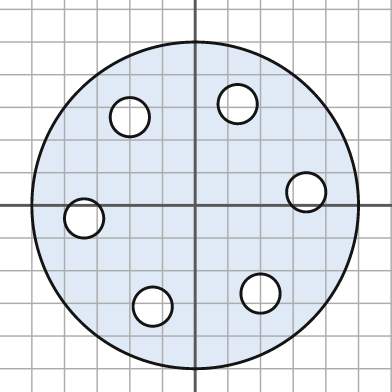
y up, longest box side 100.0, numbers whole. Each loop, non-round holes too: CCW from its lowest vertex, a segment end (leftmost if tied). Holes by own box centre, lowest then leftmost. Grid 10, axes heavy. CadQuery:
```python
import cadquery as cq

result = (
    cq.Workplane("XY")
    .moveTo(0.0, 0.0)
    .circle(50.0)
    .moveTo(-13.0, -31.0)
    .circle(6.0)
    .moveTo(20.0, -27.0)
    .circle(6.0)
    .moveTo(-34.0, -4.0)
    .circle(6.0)
    .moveTo(34.0, 4.0)
    .circle(6.0)
    .moveTo(-20.0, 27.0)
    .circle(6.0)
    .moveTo(13.0, 31.0)
    .circle(6.0)
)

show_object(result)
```